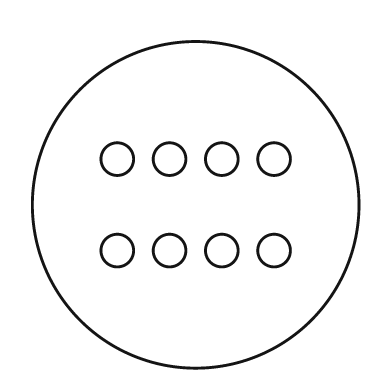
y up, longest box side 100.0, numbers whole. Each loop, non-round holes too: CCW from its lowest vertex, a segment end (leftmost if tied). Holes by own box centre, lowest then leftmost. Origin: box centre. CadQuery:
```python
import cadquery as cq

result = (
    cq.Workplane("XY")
    .moveTo(0.0, 0.0)
    .circle(50.0)
    .moveTo(-24.0, -14.0)
    .circle(5.0)
    .moveTo(-8.0, -14.0)
    .circle(5.0)
    .moveTo(8.0, -14.0)
    .circle(5.0)
    .moveTo(24.0, -14.0)
    .circle(5.0)
    .moveTo(-24.0, 14.0)
    .circle(5.0)
    .moveTo(-8.0, 14.0)
    .circle(5.0)
    .moveTo(8.0, 14.0)
    .circle(5.0)
    .moveTo(24.0, 14.0)
    .circle(5.0)
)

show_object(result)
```